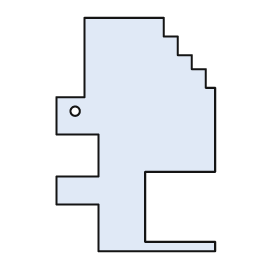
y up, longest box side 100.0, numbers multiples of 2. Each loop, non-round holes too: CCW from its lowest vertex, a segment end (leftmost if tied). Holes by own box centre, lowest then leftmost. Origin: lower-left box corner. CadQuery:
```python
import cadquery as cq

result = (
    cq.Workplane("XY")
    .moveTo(18.0, 0.0)
    .lineTo(68.0, 0.0)
    .lineTo(68.0, 4.0)
    .lineTo(38.0, 4.0)
    .lineTo(38.0, 34.0)
    .lineTo(68.0, 34.0)
    .lineTo(68.0, 70.0)
    .lineTo(64.0, 70.0)
    .lineTo(64.0, 78.0)
    .lineTo(58.0, 78.0)
    .lineTo(58.0, 84.0)
    .lineTo(52.0, 84.0)
    .lineTo(52.0, 92.0)
    .lineTo(46.0, 92.0)
    .lineTo(46.0, 100.0)
    .lineTo(12.0, 100.0)
    .lineTo(12.0, 66.0)
    .lineTo(0.0, 66.0)
    .lineTo(0.0, 50.0)
    .lineTo(18.0, 50.0)
    .lineTo(18.0, 32.0)
    .lineTo(0.0, 32.0)
    .lineTo(0.0, 20.0)
    .lineTo(18.0, 20.0)
    .close()
    .moveTo(8.0, 60.0)
    .circle(2.0)
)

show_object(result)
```